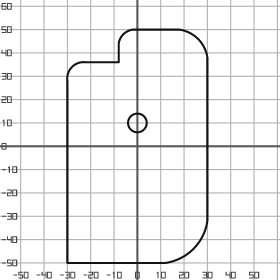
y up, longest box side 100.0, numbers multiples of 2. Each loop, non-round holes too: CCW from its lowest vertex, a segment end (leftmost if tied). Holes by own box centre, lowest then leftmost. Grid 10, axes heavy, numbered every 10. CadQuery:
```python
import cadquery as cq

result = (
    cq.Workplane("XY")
    .moveTo(-30.0, -50.0)
    .lineTo(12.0, -50.0)
    .threePointArc((24.0, -44.0), (30.0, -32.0))
    .lineTo(30.0, 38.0)
    .threePointArc((26.0, 46.0), (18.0, 50.0))
    .lineTo(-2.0, 50.0)
    .threePointArc((-6.0, 48.0), (-8.0, 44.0))
    .lineTo(-8.0, 36.0)
    .lineTo(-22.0, 36.0)
    .threePointArc((-28.0, 34.0), (-30.0, 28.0))
    .close()
    .moveTo(0.0, 10.0)
    .circle(4.0)
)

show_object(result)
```